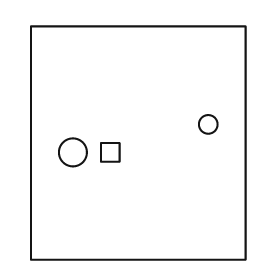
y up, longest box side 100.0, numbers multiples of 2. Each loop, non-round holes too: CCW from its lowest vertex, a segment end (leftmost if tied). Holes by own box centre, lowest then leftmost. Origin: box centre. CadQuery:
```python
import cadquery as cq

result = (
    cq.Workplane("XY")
    .moveTo(-46.0, -50.0)
    .lineTo(46.0, -50.0)
    .lineTo(46.0, 50.0)
    .lineTo(-46.0, 50.0)
    .close()
    .moveTo(-28.0, -4.0)
    .circle(6.0)
    .moveTo(-16.0, -8.0)
    .lineTo(-8.0, -8.0)
    .lineTo(-8.0, 0.0)
    .lineTo(-16.0, 0.0)
    .close()
    .moveTo(30.0, 8.0)
    .circle(4.0)
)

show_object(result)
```